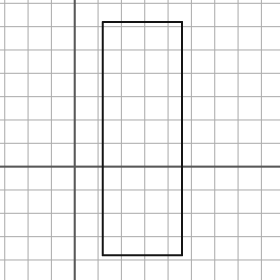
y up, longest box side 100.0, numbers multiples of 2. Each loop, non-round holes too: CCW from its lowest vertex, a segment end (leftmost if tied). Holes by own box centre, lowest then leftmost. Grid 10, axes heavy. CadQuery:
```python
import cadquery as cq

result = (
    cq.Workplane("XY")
    .moveTo(12.0, -38.0)
    .lineTo(46.0, -38.0)
    .lineTo(46.0, 62.0)
    .lineTo(12.0, 62.0)
    .close()
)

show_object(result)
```